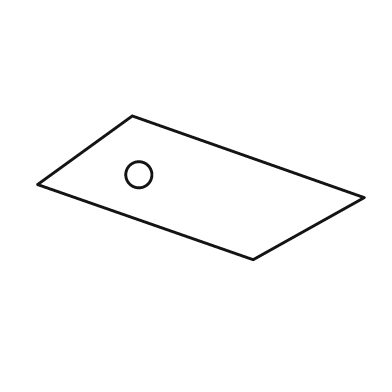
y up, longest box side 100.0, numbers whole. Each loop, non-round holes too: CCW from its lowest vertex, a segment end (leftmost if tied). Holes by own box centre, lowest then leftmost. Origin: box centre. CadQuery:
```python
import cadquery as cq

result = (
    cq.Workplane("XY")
    .moveTo(16.0, -22.0)
    .lineTo(50.0, -3.0)
    .lineTo(-21.0, 22.0)
    .lineTo(-50.0, 1.0)
    .close()
    .moveTo(-19.0, 4.0)
    .circle(4.0)
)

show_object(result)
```